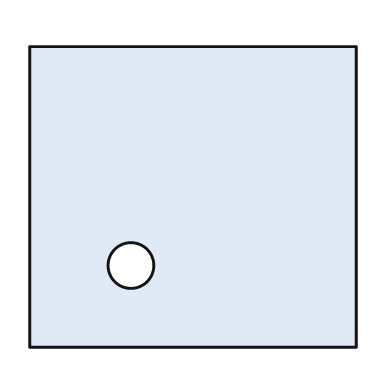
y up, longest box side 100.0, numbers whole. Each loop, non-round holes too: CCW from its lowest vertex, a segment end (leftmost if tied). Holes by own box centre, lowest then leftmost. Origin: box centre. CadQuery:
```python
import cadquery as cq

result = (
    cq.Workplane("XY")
    .moveTo(-50.0, -46.0)
    .lineTo(50.0, -46.0)
    .lineTo(50.0, 46.0)
    .lineTo(-50.0, 46.0)
    .close()
    .moveTo(-19.0, -21.0)
    .circle(7.0)
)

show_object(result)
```